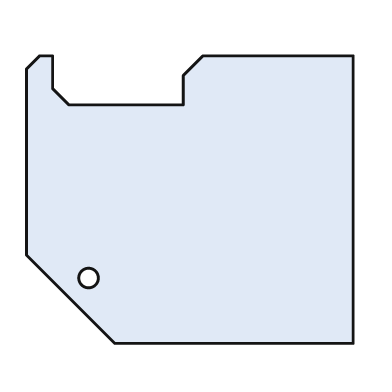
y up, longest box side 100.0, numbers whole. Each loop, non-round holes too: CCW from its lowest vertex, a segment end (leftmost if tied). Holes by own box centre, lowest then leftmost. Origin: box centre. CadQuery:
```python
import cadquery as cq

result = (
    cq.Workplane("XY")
    .moveTo(-23.0, -44.0)
    .lineTo(50.0, -44.0)
    .lineTo(50.0, 44.0)
    .lineTo(4.0, 44.0)
    .lineTo(-2.0, 38.0)
    .lineTo(-2.0, 29.0)
    .lineTo(-37.0, 29.0)
    .lineTo(-42.0, 34.0)
    .lineTo(-42.0, 44.0)
    .lineTo(-46.0, 44.0)
    .lineTo(-50.0, 40.0)
    .lineTo(-50.0, -17.0)
    .close()
    .moveTo(-31.0, -24.0)
    .circle(3.0)
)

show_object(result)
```